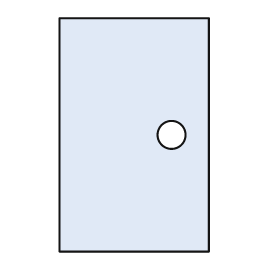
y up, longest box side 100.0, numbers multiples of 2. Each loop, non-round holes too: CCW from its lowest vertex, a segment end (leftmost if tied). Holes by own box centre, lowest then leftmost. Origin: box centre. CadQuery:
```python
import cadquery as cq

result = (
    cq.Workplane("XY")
    .moveTo(-32.0, -50.0)
    .lineTo(32.0, -50.0)
    .lineTo(32.0, 50.0)
    .lineTo(-32.0, 50.0)
    .close()
    .moveTo(16.0, 0.0)
    .circle(6.0)
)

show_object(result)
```